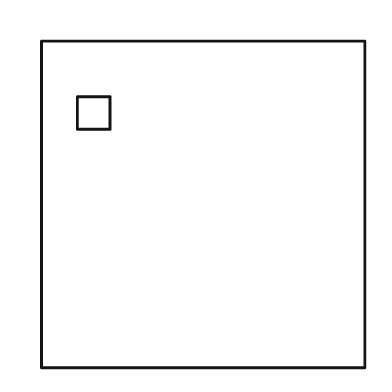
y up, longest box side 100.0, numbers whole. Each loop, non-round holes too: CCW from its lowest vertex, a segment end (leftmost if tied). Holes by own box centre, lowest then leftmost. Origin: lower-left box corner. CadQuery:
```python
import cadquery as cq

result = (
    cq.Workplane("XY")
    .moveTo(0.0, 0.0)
    .lineTo(99.0, 0.0)
    .lineTo(99.0, 100.0)
    .lineTo(0.0, 100.0)
    .close()
    .moveTo(11.0, 73.0)
    .lineTo(21.0, 73.0)
    .lineTo(21.0, 83.0)
    .lineTo(11.0, 83.0)
    .close()
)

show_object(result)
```